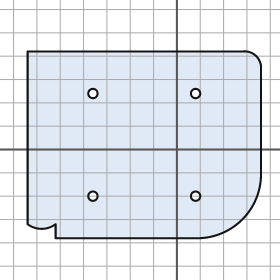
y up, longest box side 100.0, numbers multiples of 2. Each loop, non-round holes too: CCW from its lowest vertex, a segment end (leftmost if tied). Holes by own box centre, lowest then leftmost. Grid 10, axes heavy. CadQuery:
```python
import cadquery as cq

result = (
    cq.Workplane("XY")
    .moveTo(-52.0, -38.0)
    .lineTo(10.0, -38.0)
    .threePointArc((28.0, -30.0), (36.0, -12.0))
    .lineTo(36.0, 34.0)
    .threePointArc((34.0, 40.0), (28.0, 42.0))
    .lineTo(-64.0, 42.0)
    .lineTo(-64.0, -32.0)
    .threePointArc((-58.0, -34.0), (-52.0, -32.0))
    .close()
    .moveTo(-36.0, -20.0)
    .circle(2.0)
    .moveTo(8.0, -20.0)
    .circle(2.0)
    .moveTo(-36.0, 24.0)
    .circle(2.0)
    .moveTo(8.0, 24.0)
    .circle(2.0)
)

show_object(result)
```